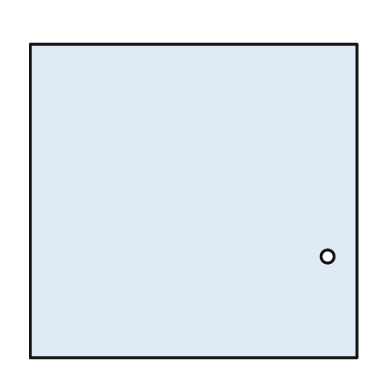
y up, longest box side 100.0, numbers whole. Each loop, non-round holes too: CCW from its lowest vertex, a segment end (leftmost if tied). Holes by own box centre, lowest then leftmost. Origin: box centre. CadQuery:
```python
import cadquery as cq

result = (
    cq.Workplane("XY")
    .moveTo(-50.0, -48.0)
    .lineTo(50.0, -48.0)
    .lineTo(50.0, 48.0)
    .lineTo(-50.0, 48.0)
    .close()
    .moveTo(41.0, -17.0)
    .circle(2.0)
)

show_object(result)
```